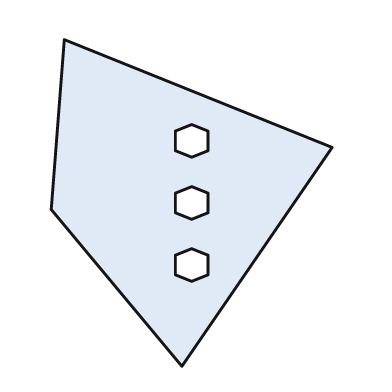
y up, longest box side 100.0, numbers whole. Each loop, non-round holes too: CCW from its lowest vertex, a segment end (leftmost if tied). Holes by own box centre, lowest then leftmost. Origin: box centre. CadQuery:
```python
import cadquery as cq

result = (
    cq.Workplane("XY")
    .moveTo(-3.0, -50.0)
    .lineTo(43.0, 17.0)
    .lineTo(-39.0, 50.0)
    .lineTo(-43.0, -2.0)
    .close()
    .moveTo(0.0, -24.0)
    .lineTo(5.0, -22.0)
    .lineTo(5.0, -16.0)
    .lineTo(0.0, -14.0)
    .lineTo(-5.0, -16.0)
    .lineTo(-5.0, -22.0)
    .close()
    .moveTo(0.0, -5.0)
    .lineTo(5.0, -3.0)
    .lineTo(5.0, 3.0)
    .lineTo(0.0, 5.0)
    .lineTo(-5.0, 3.0)
    .lineTo(-5.0, -3.0)
    .close()
    .moveTo(0.0, 14.0)
    .lineTo(5.0, 16.0)
    .lineTo(5.0, 22.0)
    .lineTo(0.0, 24.0)
    .lineTo(-5.0, 22.0)
    .lineTo(-5.0, 16.0)
    .close()
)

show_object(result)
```